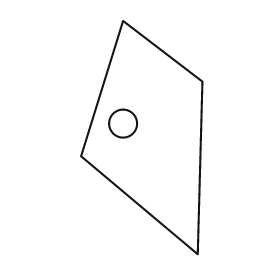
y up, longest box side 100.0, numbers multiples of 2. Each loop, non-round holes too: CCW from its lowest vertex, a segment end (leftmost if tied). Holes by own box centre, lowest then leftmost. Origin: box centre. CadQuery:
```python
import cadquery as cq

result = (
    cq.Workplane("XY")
    .moveTo(24.0, -50.0)
    .lineTo(26.0, 24.0)
    .lineTo(-8.0, 50.0)
    .lineTo(-26.0, -8.0)
    .close()
    .moveTo(-8.0, 6.0)
    .circle(6.0)
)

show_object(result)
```